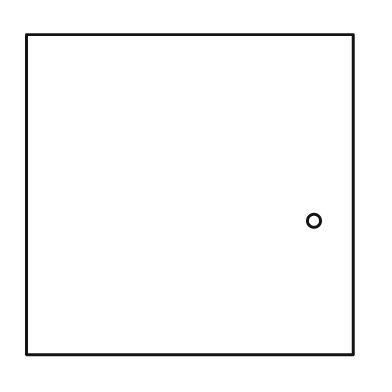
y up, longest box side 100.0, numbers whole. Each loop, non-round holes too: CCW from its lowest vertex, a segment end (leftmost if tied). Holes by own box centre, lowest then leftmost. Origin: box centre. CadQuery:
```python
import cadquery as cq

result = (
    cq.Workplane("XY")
    .moveTo(-50.0, -49.0)
    .lineTo(50.0, -49.0)
    .lineTo(50.0, 49.0)
    .lineTo(-50.0, 49.0)
    .close()
    .moveTo(38.0, -8.0)
    .circle(2.0)
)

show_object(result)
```